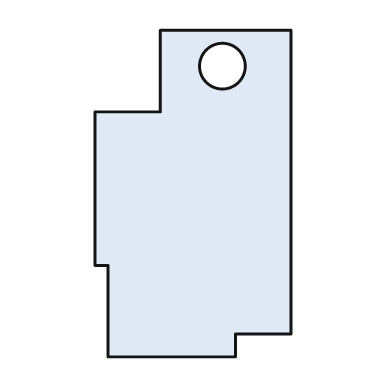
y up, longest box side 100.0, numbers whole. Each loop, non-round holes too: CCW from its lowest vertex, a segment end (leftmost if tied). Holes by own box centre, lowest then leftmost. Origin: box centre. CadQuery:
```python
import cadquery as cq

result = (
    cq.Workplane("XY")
    .moveTo(-26.0, -50.0)
    .lineTo(13.0, -50.0)
    .lineTo(13.0, -43.0)
    .lineTo(30.0, -43.0)
    .lineTo(30.0, 50.0)
    .lineTo(-10.0, 50.0)
    .lineTo(-10.0, 25.0)
    .lineTo(-30.0, 25.0)
    .lineTo(-30.0, -22.0)
    .lineTo(-26.0, -22.0)
    .close()
    .moveTo(9.0, 39.0)
    .circle(7.0)
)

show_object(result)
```